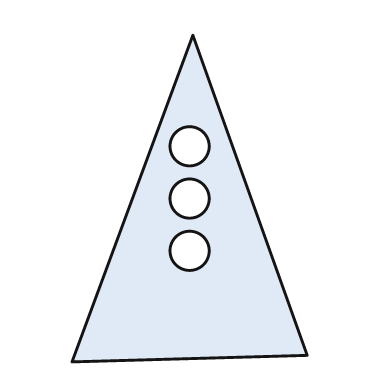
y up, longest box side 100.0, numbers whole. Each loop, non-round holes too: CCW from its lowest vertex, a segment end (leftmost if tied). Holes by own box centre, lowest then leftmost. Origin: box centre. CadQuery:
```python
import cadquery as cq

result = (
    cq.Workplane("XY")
    .moveTo(-36.0, -50.0)
    .lineTo(36.0, -48.0)
    .lineTo(1.0, 50.0)
    .close()
    .moveTo(0.0, -16.0)
    .circle(6.0)
    .moveTo(0.0, 0.0)
    .circle(6.0)
    .moveTo(0.0, 16.0)
    .circle(6.0)
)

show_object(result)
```